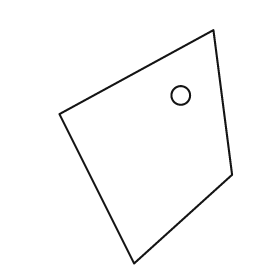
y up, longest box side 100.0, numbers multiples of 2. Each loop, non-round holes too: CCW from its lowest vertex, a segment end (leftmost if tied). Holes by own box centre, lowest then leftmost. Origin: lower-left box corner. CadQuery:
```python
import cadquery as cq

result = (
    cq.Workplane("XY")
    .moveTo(32.0, 0.0)
    .lineTo(74.0, 38.0)
    .lineTo(66.0, 100.0)
    .lineTo(0.0, 64.0)
    .close()
    .moveTo(52.0, 72.0)
    .circle(4.0)
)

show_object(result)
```